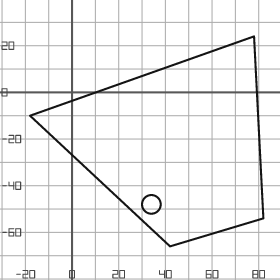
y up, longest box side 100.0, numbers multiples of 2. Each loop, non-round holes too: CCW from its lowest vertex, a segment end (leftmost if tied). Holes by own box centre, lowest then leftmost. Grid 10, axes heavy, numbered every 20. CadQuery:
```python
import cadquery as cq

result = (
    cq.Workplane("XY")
    .moveTo(42.0, -66.0)
    .lineTo(82.0, -54.0)
    .lineTo(78.0, 24.0)
    .lineTo(-18.0, -10.0)
    .close()
    .moveTo(34.0, -48.0)
    .circle(4.0)
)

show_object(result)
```